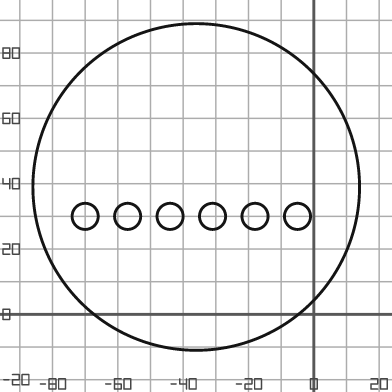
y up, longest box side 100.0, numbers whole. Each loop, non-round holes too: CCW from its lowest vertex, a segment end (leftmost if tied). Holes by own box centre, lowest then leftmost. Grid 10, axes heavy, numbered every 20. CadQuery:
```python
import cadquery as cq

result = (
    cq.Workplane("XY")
    .moveTo(-36.0, 39.0)
    .circle(50.0)
    .moveTo(-70.0, 30.0)
    .circle(4.0)
    .moveTo(-57.0, 30.0)
    .circle(4.0)
    .moveTo(-44.0, 30.0)
    .circle(4.0)
    .moveTo(-31.0, 30.0)
    .circle(4.0)
    .moveTo(-18.0, 30.0)
    .circle(4.0)
    .moveTo(-5.0, 30.0)
    .circle(4.0)
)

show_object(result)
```